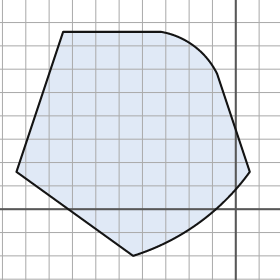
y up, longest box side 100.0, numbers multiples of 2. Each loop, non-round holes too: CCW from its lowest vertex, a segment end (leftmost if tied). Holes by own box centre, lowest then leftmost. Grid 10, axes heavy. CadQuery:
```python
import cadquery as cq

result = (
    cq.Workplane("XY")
    .moveTo(-44.0, -20.0)
    .threePointArc((-16.0, -6.0), (6.0, 16.0))
    .lineTo(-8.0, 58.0)
    .threePointArc((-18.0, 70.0), (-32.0, 76.0))
    .lineTo(-74.0, 76.0)
    .lineTo(-94.0, 16.0)
    .close()
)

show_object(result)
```